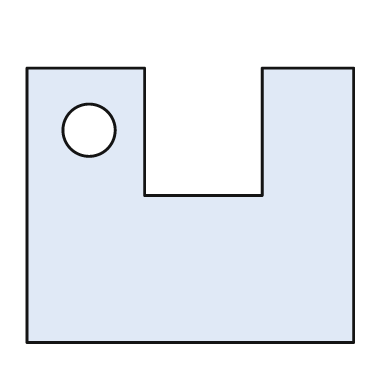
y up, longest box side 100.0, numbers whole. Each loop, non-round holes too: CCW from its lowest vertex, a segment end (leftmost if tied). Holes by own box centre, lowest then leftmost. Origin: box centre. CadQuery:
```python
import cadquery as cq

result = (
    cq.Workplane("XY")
    .moveTo(-50.0, -42.0)
    .lineTo(50.0, -42.0)
    .lineTo(50.0, 42.0)
    .lineTo(22.0, 42.0)
    .lineTo(22.0, 3.0)
    .lineTo(-14.0, 3.0)
    .lineTo(-14.0, 42.0)
    .lineTo(-50.0, 42.0)
    .close()
    .moveTo(-31.0, 23.0)
    .circle(8.0)
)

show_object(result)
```